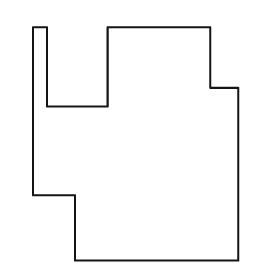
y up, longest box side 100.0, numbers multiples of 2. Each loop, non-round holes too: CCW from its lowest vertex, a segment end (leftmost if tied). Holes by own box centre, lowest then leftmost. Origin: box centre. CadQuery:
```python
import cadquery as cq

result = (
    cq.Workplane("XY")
    .moveTo(-26.0, -50.0)
    .lineTo(44.0, -50.0)
    .lineTo(44.0, 24.0)
    .lineTo(32.0, 24.0)
    .lineTo(32.0, 50.0)
    .lineTo(-12.0, 50.0)
    .lineTo(-12.0, 16.0)
    .lineTo(-38.0, 16.0)
    .lineTo(-38.0, 50.0)
    .lineTo(-44.0, 50.0)
    .lineTo(-44.0, -22.0)
    .lineTo(-26.0, -22.0)
    .close()
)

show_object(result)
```